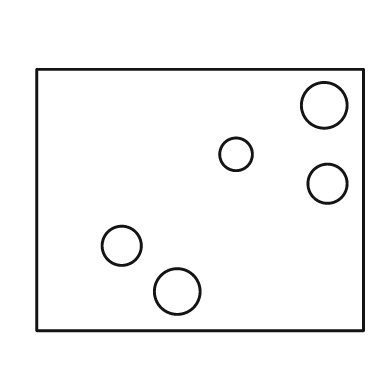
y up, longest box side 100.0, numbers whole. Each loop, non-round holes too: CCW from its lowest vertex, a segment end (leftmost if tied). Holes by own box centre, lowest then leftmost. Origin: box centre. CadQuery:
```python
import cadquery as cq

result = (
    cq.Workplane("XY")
    .moveTo(-50.0, -40.0)
    .lineTo(50.0, -40.0)
    .lineTo(50.0, 40.0)
    .lineTo(-50.0, 40.0)
    .close()
    .moveTo(-7.0, -28.0)
    .circle(7.0)
    .moveTo(-24.0, -14.0)
    .circle(6.0)
    .moveTo(39.0, 5.0)
    .circle(6.0)
    .moveTo(11.0, 14.0)
    .circle(5.0)
    .moveTo(38.0, 29.0)
    .circle(7.0)
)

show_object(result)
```